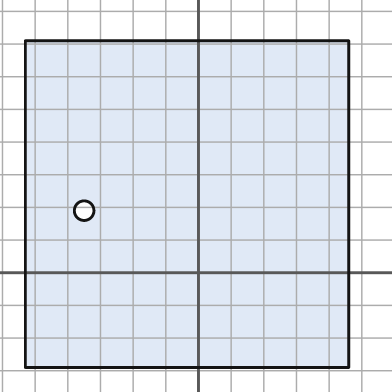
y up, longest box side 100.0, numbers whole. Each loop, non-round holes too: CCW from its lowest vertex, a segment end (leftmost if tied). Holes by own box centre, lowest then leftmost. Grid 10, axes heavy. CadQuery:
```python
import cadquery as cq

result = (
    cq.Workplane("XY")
    .moveTo(-53.0, -29.0)
    .lineTo(46.0, -29.0)
    .lineTo(46.0, 71.0)
    .lineTo(-53.0, 71.0)
    .close()
    .moveTo(-35.0, 19.0)
    .circle(3.0)
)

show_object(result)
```